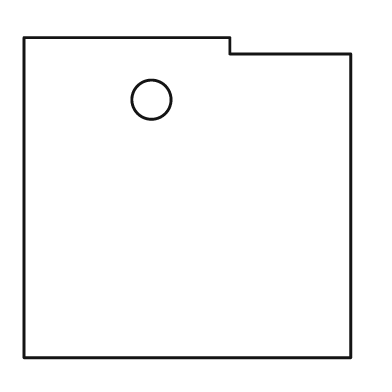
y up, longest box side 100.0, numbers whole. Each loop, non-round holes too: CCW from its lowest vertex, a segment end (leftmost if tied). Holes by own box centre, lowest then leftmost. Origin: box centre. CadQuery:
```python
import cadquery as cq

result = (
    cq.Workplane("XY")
    .moveTo(-50.0, -49.0)
    .lineTo(50.0, -49.0)
    .lineTo(50.0, 44.0)
    .lineTo(13.0, 44.0)
    .lineTo(13.0, 49.0)
    .lineTo(-50.0, 49.0)
    .close()
    .moveTo(-11.0, 30.0)
    .circle(6.0)
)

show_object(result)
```